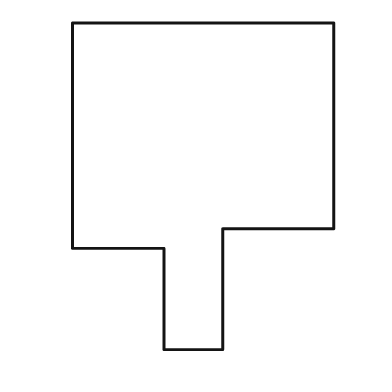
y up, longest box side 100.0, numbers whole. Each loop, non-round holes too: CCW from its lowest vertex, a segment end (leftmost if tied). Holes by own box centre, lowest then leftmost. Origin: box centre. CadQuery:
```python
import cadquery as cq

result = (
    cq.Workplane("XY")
    .moveTo(-12.0, -50.0)
    .lineTo(6.0, -50.0)
    .lineTo(6.0, -13.0)
    .lineTo(40.0, -13.0)
    .lineTo(40.0, 50.0)
    .lineTo(-40.0, 50.0)
    .lineTo(-40.0, -19.0)
    .lineTo(-12.0, -19.0)
    .close()
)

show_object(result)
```